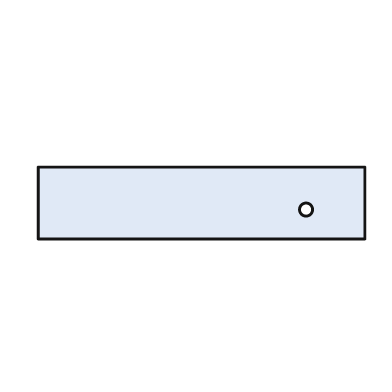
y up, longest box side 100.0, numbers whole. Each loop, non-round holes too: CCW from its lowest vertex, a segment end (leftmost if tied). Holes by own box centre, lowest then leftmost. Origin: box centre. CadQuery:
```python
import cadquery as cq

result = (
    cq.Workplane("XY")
    .moveTo(-50.0, -11.0)
    .lineTo(50.0, -11.0)
    .lineTo(50.0, 11.0)
    .lineTo(-50.0, 11.0)
    .close()
    .moveTo(32.0, -2.0)
    .circle(2.0)
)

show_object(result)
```